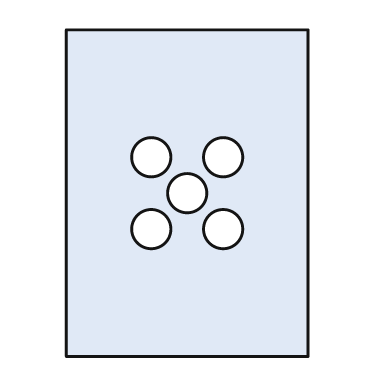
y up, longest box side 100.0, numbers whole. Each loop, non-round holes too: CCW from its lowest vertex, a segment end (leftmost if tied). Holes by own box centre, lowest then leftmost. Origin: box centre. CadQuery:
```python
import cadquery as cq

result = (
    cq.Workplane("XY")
    .moveTo(-37.0, -50.0)
    .lineTo(37.0, -50.0)
    .lineTo(37.0, 50.0)
    .lineTo(-37.0, 50.0)
    .close()
    .moveTo(-11.0, -11.0)
    .circle(6.0)
    .moveTo(11.0, -11.0)
    .circle(6.0)
    .moveTo(0.0, 0.0)
    .circle(6.0)
    .moveTo(-11.0, 11.0)
    .circle(6.0)
    .moveTo(11.0, 11.0)
    .circle(6.0)
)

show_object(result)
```